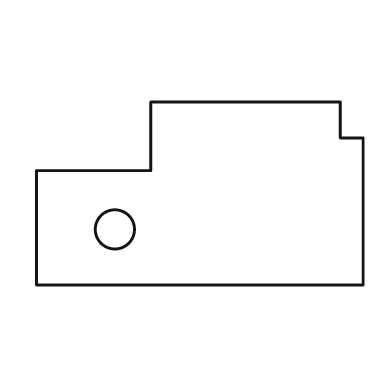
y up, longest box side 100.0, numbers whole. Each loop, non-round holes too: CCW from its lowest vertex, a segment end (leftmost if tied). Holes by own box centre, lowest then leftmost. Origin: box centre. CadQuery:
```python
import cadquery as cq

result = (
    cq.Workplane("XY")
    .moveTo(-50.0, -28.0)
    .lineTo(50.0, -28.0)
    .lineTo(50.0, 17.0)
    .lineTo(43.0, 17.0)
    .lineTo(43.0, 28.0)
    .lineTo(-15.0, 28.0)
    .lineTo(-15.0, 7.0)
    .lineTo(-50.0, 7.0)
    .close()
    .moveTo(-26.0, -11.0)
    .circle(6.0)
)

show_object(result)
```